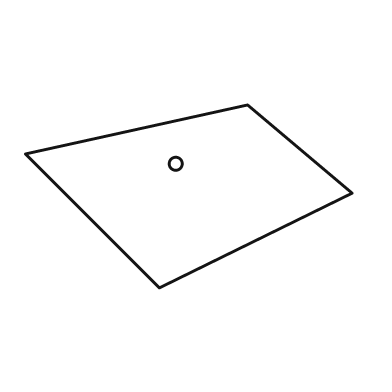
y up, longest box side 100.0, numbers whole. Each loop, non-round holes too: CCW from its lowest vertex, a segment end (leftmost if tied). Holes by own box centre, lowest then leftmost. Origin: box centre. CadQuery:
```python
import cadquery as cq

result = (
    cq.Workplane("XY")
    .moveTo(-9.0, -28.0)
    .lineTo(50.0, 1.0)
    .lineTo(18.0, 28.0)
    .lineTo(-50.0, 13.0)
    .close()
    .moveTo(-4.0, 10.0)
    .circle(2.0)
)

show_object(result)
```